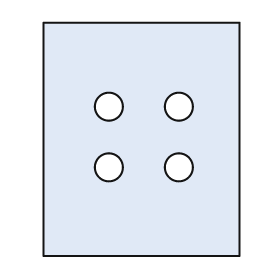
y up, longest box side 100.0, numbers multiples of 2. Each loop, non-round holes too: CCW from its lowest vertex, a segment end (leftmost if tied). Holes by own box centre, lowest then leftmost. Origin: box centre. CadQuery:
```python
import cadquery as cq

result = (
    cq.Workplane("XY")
    .moveTo(-42.0, -50.0)
    .lineTo(42.0, -50.0)
    .lineTo(42.0, 50.0)
    .lineTo(-42.0, 50.0)
    .close()
    .moveTo(-14.0, -12.0)
    .circle(6.0)
    .moveTo(16.0, -12.0)
    .circle(6.0)
    .moveTo(-14.0, 14.0)
    .circle(6.0)
    .moveTo(16.0, 14.0)
    .circle(6.0)
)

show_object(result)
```